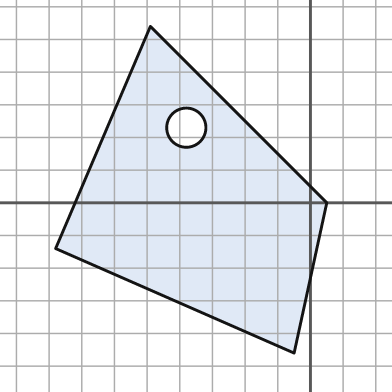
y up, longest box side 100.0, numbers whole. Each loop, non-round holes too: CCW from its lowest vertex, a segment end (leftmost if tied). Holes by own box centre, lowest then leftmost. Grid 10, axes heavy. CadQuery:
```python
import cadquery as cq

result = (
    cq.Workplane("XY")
    .moveTo(-5.0, -46.0)
    .lineTo(5.0, 0.0)
    .lineTo(-49.0, 54.0)
    .lineTo(-78.0, -14.0)
    .close()
    .moveTo(-38.0, 23.0)
    .circle(6.0)
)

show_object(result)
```